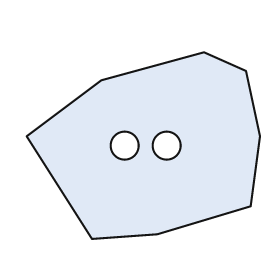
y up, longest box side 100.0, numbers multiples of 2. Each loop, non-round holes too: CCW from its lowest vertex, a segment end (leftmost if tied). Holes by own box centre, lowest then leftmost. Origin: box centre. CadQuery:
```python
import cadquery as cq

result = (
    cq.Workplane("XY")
    .moveTo(-22.0, -40.0)
    .lineTo(6.0, -38.0)
    .lineTo(46.0, -26.0)
    .lineTo(50.0, 4.0)
    .lineTo(44.0, 32.0)
    .lineTo(26.0, 40.0)
    .lineTo(-18.0, 28.0)
    .lineTo(-50.0, 4.0)
    .close()
    .moveTo(-8.0, 0.0)
    .circle(6.0)
    .moveTo(10.0, 0.0)
    .circle(6.0)
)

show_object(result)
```